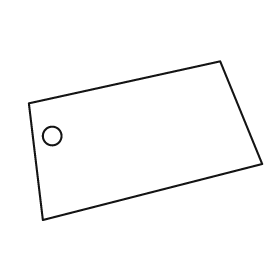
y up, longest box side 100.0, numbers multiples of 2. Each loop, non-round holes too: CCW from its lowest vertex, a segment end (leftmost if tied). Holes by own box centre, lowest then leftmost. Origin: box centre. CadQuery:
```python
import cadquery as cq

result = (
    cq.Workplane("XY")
    .moveTo(-44.0, -34.0)
    .lineTo(50.0, -10.0)
    .lineTo(32.0, 34.0)
    .lineTo(-50.0, 16.0)
    .close()
    .moveTo(-40.0, 2.0)
    .circle(4.0)
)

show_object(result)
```